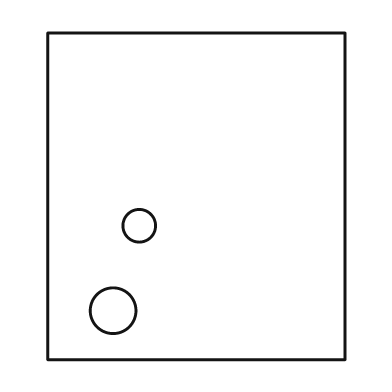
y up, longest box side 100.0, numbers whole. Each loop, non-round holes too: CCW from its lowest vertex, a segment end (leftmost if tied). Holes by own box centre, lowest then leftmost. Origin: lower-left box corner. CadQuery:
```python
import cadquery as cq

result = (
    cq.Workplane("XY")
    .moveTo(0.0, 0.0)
    .lineTo(91.0, 0.0)
    .lineTo(91.0, 100.0)
    .lineTo(0.0, 100.0)
    .close()
    .moveTo(20.0, 15.0)
    .circle(7.0)
    .moveTo(28.0, 41.0)
    .circle(5.0)
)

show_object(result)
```